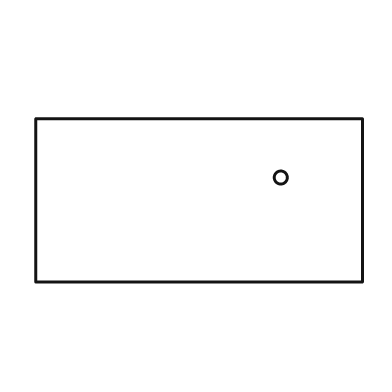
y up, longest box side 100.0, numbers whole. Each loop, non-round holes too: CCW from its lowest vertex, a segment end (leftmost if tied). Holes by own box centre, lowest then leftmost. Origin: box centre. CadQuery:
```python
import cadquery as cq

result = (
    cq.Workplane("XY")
    .moveTo(-50.0, -25.0)
    .lineTo(50.0, -25.0)
    .lineTo(50.0, 25.0)
    .lineTo(-50.0, 25.0)
    .close()
    .moveTo(25.0, 7.0)
    .circle(2.0)
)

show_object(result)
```